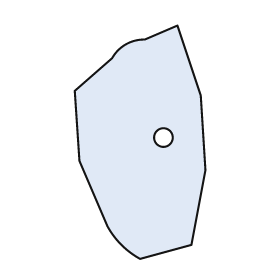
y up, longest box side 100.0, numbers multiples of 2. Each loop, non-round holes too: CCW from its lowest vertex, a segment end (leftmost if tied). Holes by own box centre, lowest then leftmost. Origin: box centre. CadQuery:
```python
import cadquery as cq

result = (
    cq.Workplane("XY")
    .moveTo(0.0, -50.0)
    .lineTo(22.0, -44.0)
    .lineTo(28.0, -12.0)
    .lineTo(26.0, 20.0)
    .lineTo(16.0, 50.0)
    .lineTo(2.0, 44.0)
    .threePointArc((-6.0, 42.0), (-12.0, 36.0))
    .lineTo(-28.0, 22.0)
    .lineTo(-26.0, -8.0)
    .lineTo(-14.0, -36.0)
    .threePointArc((-8.0, -44.0), (0.0, -50.0))
    .close()
    .moveTo(10.0, 2.0)
    .circle(4.0)
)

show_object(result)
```